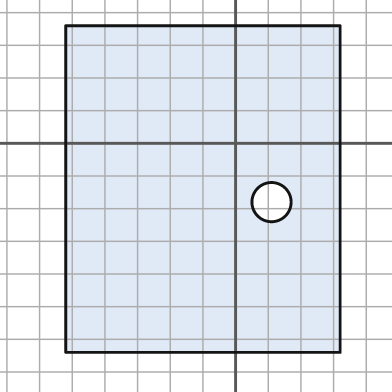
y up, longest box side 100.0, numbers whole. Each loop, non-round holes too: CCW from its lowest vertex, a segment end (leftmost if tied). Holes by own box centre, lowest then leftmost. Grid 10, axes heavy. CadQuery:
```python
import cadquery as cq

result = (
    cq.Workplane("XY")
    .moveTo(-52.0, -64.0)
    .lineTo(32.0, -64.0)
    .lineTo(32.0, 36.0)
    .lineTo(-52.0, 36.0)
    .close()
    .moveTo(11.0, -18.0)
    .circle(6.0)
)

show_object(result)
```